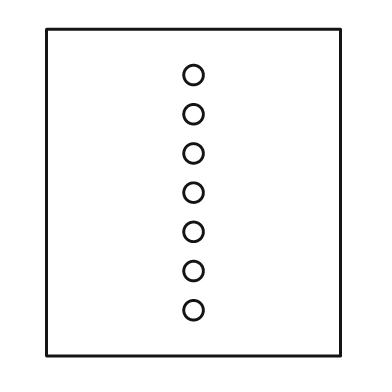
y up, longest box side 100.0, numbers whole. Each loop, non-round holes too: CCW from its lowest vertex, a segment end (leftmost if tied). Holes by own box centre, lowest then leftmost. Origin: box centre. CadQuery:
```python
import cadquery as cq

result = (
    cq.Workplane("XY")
    .moveTo(-45.0, -50.0)
    .lineTo(45.0, -50.0)
    .lineTo(45.0, 50.0)
    .lineTo(-45.0, 50.0)
    .close()
    .moveTo(0.0, -36.0)
    .circle(3.0)
    .moveTo(0.0, -24.0)
    .circle(3.0)
    .moveTo(0.0, -12.0)
    .circle(3.0)
    .moveTo(0.0, 0.0)
    .circle(3.0)
    .moveTo(0.0, 12.0)
    .circle(3.0)
    .moveTo(0.0, 24.0)
    .circle(3.0)
    .moveTo(0.0, 36.0)
    .circle(3.0)
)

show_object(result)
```